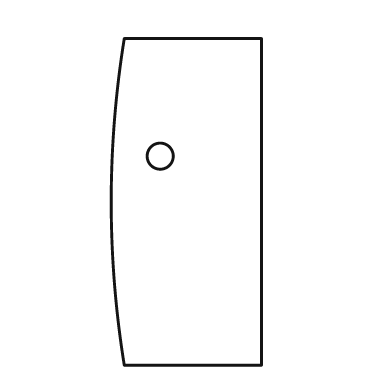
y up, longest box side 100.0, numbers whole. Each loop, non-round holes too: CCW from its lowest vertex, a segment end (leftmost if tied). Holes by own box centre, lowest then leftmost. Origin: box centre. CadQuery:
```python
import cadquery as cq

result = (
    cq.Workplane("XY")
    .moveTo(-19.0, -50.0)
    .lineTo(23.0, -50.0)
    .lineTo(23.0, 50.0)
    .lineTo(-19.0, 50.0)
    .threePointArc((-23.0, 0.0), (-19.0, -50.0))
    .close()
    .moveTo(-8.0, 14.0)
    .circle(4.0)
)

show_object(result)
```